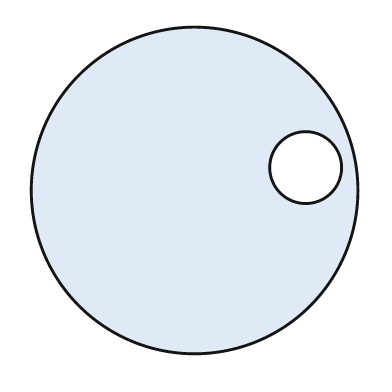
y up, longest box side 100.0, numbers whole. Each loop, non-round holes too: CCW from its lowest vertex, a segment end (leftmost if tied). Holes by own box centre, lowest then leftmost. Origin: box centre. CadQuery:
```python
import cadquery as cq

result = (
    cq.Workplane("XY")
    .moveTo(0.0, 0.0)
    .circle(50.0)
    .moveTo(34.0, 7.0)
    .circle(11.0)
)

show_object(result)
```